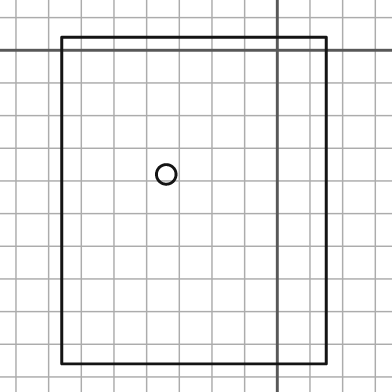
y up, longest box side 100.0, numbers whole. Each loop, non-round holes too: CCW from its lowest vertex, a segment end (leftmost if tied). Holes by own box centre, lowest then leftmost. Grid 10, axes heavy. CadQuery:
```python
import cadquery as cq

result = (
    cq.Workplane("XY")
    .moveTo(-66.0, -96.0)
    .lineTo(15.0, -96.0)
    .lineTo(15.0, 4.0)
    .lineTo(-66.0, 4.0)
    .close()
    .moveTo(-34.0, -38.0)
    .circle(3.0)
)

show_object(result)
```